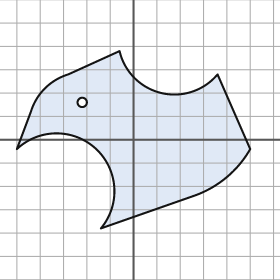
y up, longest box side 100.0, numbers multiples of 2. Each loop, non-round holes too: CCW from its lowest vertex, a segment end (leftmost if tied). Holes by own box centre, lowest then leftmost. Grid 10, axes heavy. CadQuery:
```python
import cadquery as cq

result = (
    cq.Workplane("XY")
    .moveTo(-14.0, -38.0)
    .lineTo(26.0, -24.0)
    .threePointArc((40.0, -16.0), (50.0, -4.0))
    .lineTo(36.0, 28.0)
    .threePointArc((12.0, 20.0), (-6.0, 38.0))
    .lineTo(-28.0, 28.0)
    .threePointArc((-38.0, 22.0), (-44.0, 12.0))
    .lineTo(-50.0, -4.0)
    .threePointArc((-16.0, -4.0), (-14.0, -38.0))
    .close()
    .moveTo(-22.0, 16.0)
    .circle(2.0)
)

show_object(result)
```